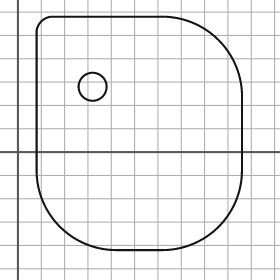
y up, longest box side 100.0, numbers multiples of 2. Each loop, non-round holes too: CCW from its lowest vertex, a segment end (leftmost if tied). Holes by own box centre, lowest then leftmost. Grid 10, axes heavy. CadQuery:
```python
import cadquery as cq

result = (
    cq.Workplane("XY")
    .moveTo(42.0, -42.0)
    .lineTo(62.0, -42.0)
    .threePointArc((86.0, -32.0), (96.0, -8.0))
    .lineTo(96.0, 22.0)
    .threePointArc((86.0, 48.0), (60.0, 58.0))
    .lineTo(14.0, 58.0)
    .threePointArc((10.0, 56.0), (8.0, 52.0))
    .lineTo(8.0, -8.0)
    .threePointArc((18.0, -32.0), (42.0, -42.0))
    .close()
    .moveTo(32.0, 28.0)
    .circle(6.0)
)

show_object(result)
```